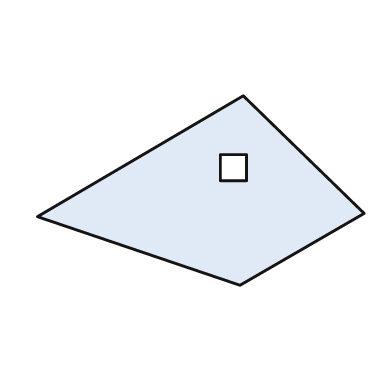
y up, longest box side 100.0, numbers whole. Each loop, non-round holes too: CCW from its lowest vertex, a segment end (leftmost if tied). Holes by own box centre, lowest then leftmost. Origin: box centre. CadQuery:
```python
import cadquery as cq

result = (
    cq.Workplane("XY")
    .moveTo(12.0, -29.0)
    .lineTo(50.0, -7.0)
    .lineTo(13.0, 29.0)
    .lineTo(-50.0, -8.0)
    .close()
    .moveTo(6.0, 3.0)
    .lineTo(14.0, 3.0)
    .lineTo(14.0, 11.0)
    .lineTo(6.0, 11.0)
    .close()
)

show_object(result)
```